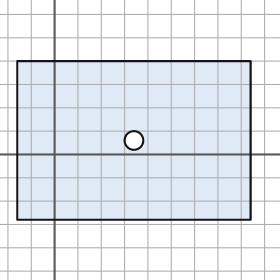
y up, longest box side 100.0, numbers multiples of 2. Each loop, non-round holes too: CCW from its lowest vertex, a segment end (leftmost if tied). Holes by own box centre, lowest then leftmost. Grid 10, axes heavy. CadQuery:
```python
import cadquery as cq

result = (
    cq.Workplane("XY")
    .moveTo(-16.0, -28.0)
    .lineTo(84.0, -28.0)
    .lineTo(84.0, 40.0)
    .lineTo(-16.0, 40.0)
    .close()
    .moveTo(34.0, 6.0)
    .circle(4.0)
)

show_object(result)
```